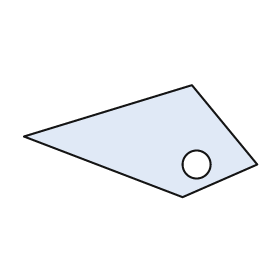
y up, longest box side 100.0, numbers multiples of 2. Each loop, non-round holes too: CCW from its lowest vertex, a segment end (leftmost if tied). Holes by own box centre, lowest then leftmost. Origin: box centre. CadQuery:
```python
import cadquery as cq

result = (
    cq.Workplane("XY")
    .moveTo(18.0, -24.0)
    .lineTo(50.0, -10.0)
    .lineTo(22.0, 24.0)
    .lineTo(-50.0, 2.0)
    .close()
    .moveTo(24.0, -10.0)
    .circle(6.0)
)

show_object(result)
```